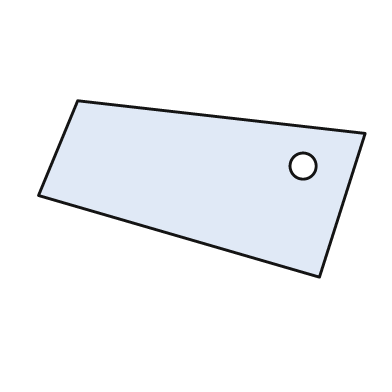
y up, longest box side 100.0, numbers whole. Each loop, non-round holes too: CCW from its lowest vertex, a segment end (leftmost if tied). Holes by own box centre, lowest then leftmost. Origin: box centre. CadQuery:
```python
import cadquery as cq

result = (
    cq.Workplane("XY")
    .moveTo(36.0, -27.0)
    .lineTo(50.0, 17.0)
    .lineTo(-38.0, 27.0)
    .lineTo(-50.0, -2.0)
    .close()
    .moveTo(31.0, 7.0)
    .circle(4.0)
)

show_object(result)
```